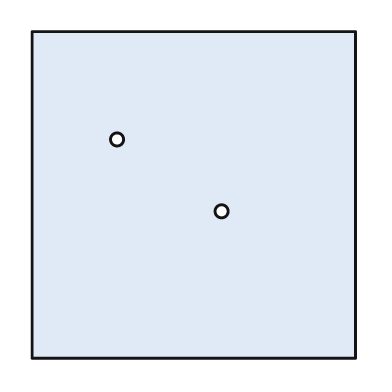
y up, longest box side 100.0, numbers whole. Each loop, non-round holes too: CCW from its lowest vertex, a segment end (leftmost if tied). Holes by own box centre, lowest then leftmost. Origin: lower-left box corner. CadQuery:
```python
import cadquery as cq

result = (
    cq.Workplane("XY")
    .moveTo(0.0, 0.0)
    .lineTo(99.0, 0.0)
    .lineTo(99.0, 100.0)
    .lineTo(0.0, 100.0)
    .close()
    .moveTo(58.0, 45.0)
    .circle(2.0)
    .moveTo(26.0, 67.0)
    .circle(2.0)
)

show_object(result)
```